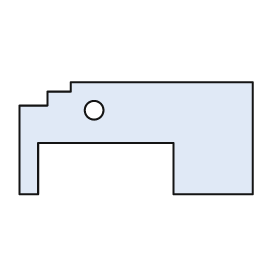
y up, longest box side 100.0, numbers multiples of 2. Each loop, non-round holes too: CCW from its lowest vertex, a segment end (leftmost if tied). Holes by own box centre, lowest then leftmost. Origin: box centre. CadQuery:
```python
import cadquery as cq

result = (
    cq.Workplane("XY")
    .moveTo(-50.0, -24.0)
    .lineTo(-42.0, -24.0)
    .lineTo(-42.0, -2.0)
    .lineTo(16.0, -2.0)
    .lineTo(16.0, -24.0)
    .lineTo(50.0, -24.0)
    .lineTo(50.0, 24.0)
    .lineTo(-28.0, 24.0)
    .lineTo(-28.0, 20.0)
    .lineTo(-38.0, 20.0)
    .lineTo(-38.0, 14.0)
    .lineTo(-50.0, 14.0)
    .close()
    .moveTo(-18.0, 12.0)
    .circle(4.0)
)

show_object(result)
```